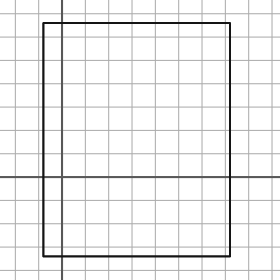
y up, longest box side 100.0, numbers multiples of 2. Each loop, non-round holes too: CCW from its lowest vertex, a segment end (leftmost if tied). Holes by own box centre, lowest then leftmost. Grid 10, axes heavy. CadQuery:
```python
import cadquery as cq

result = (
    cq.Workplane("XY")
    .moveTo(-8.0, -34.0)
    .lineTo(72.0, -34.0)
    .lineTo(72.0, 66.0)
    .lineTo(-8.0, 66.0)
    .close()
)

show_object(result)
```